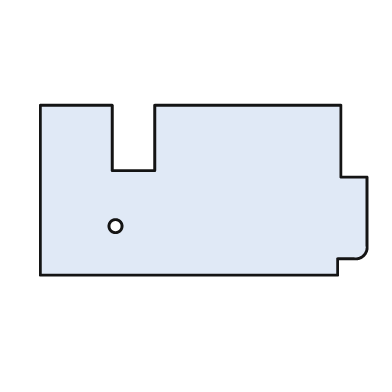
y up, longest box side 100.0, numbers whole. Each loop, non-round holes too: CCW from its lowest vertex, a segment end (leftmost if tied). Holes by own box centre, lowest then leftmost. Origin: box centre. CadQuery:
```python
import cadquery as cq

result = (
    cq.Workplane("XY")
    .moveTo(-50.0, -26.0)
    .lineTo(41.0, -26.0)
    .lineTo(41.0, -21.0)
    .lineTo(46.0, -21.0)
    .threePointArc((49.0, -20.0), (50.0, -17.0))
    .lineTo(50.0, 4.0)
    .lineTo(42.0, 4.0)
    .lineTo(42.0, 26.0)
    .lineTo(-15.0, 26.0)
    .lineTo(-15.0, 6.0)
    .lineTo(-28.0, 6.0)
    .lineTo(-28.0, 26.0)
    .lineTo(-50.0, 26.0)
    .close()
    .moveTo(-27.0, -11.0)
    .circle(2.0)
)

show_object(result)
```